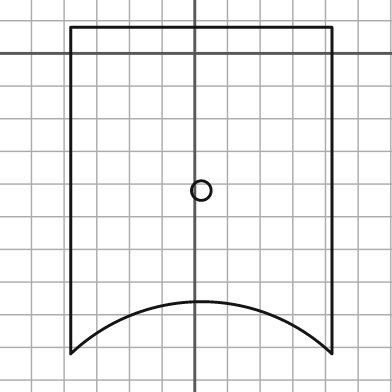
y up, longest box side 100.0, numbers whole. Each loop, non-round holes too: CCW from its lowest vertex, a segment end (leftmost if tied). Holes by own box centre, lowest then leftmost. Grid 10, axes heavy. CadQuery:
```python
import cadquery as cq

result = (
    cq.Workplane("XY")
    .moveTo(-38.0, -92.0)
    .threePointArc((2.0, -76.0), (42.0, -92.0))
    .lineTo(42.0, 8.0)
    .lineTo(-38.0, 8.0)
    .close()
    .moveTo(2.0, -42.0)
    .circle(3.0)
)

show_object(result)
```